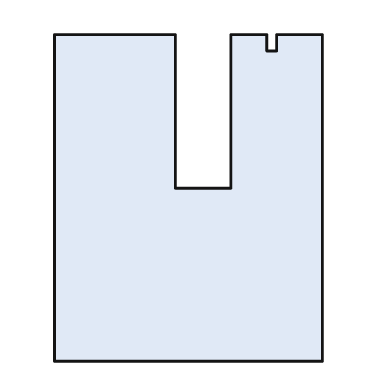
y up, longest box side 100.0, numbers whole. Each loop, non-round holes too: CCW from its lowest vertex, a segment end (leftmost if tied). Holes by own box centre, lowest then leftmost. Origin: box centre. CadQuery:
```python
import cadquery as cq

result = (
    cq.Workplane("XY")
    .moveTo(-41.0, -50.0)
    .lineTo(41.0, -50.0)
    .lineTo(41.0, 50.0)
    .lineTo(27.0, 50.0)
    .lineTo(27.0, 45.0)
    .lineTo(24.0, 45.0)
    .lineTo(24.0, 50.0)
    .lineTo(13.0, 50.0)
    .lineTo(13.0, 3.0)
    .lineTo(-4.0, 3.0)
    .lineTo(-4.0, 50.0)
    .lineTo(-41.0, 50.0)
    .close()
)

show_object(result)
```